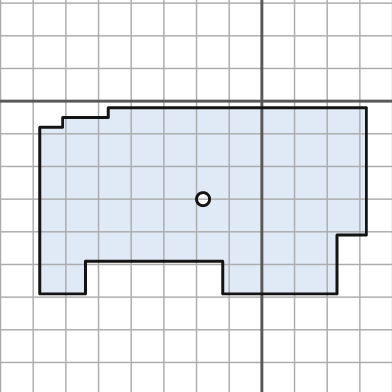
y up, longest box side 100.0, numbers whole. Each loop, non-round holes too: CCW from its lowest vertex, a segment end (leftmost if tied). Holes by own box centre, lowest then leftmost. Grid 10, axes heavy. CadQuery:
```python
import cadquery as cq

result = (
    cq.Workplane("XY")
    .moveTo(-68.0, -59.0)
    .lineTo(-54.0, -59.0)
    .lineTo(-54.0, -49.0)
    .lineTo(-12.0, -49.0)
    .lineTo(-12.0, -59.0)
    .lineTo(23.0, -59.0)
    .lineTo(23.0, -41.0)
    .lineTo(32.0, -41.0)
    .lineTo(32.0, -2.0)
    .lineTo(-47.0, -2.0)
    .lineTo(-47.0, -5.0)
    .lineTo(-61.0, -5.0)
    .lineTo(-61.0, -8.0)
    .lineTo(-68.0, -8.0)
    .close()
    .moveTo(-18.0, -30.0)
    .circle(2.0)
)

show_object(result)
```